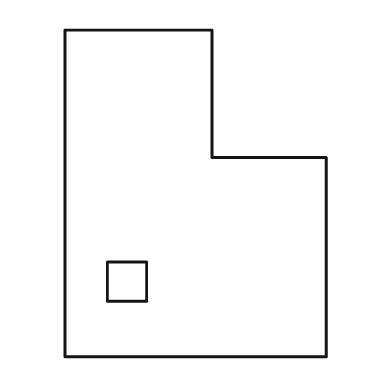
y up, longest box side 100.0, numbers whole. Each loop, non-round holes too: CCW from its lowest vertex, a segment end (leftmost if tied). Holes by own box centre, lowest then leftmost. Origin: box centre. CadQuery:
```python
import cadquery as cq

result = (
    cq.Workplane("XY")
    .moveTo(-40.0, -50.0)
    .lineTo(40.0, -50.0)
    .lineTo(40.0, 11.0)
    .lineTo(5.0, 11.0)
    .lineTo(5.0, 50.0)
    .lineTo(-40.0, 50.0)
    .close()
    .moveTo(-27.0, -33.0)
    .lineTo(-15.0, -33.0)
    .lineTo(-15.0, -21.0)
    .lineTo(-27.0, -21.0)
    .close()
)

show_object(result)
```